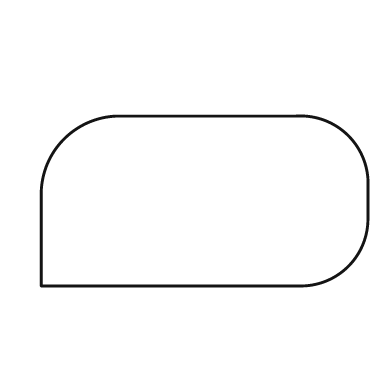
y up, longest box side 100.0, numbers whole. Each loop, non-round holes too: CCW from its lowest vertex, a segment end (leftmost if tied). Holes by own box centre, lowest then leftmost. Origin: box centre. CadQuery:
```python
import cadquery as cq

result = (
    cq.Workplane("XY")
    .moveTo(-50.0, -26.0)
    .lineTo(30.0, -26.0)
    .threePointArc((44.0, -20.0), (50.0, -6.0))
    .lineTo(50.0, 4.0)
    .threePointArc((44.0, 20.0), (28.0, 26.0))
    .lineTo(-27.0, 26.0)
    .threePointArc((-43.0, 19.0), (-50.0, 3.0))
    .close()
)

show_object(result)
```